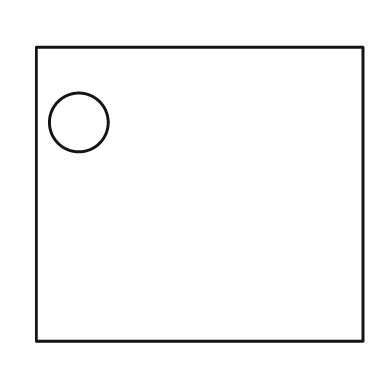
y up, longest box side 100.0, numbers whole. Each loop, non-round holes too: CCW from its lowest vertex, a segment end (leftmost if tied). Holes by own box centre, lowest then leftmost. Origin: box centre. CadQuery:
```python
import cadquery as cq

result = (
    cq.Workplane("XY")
    .moveTo(-50.0, -45.0)
    .lineTo(50.0, -45.0)
    .lineTo(50.0, 45.0)
    .lineTo(-50.0, 45.0)
    .close()
    .moveTo(-37.0, 22.0)
    .circle(9.0)
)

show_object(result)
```